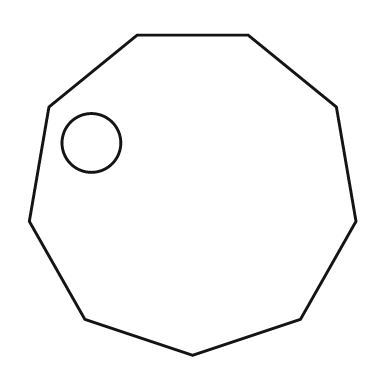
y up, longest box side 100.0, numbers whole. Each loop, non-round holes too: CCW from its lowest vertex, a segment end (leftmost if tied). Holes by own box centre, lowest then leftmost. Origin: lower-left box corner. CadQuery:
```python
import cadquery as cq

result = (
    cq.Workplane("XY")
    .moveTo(50.0, 0.0)
    .lineTo(83.0, 11.0)
    .lineTo(100.0, 41.0)
    .lineTo(94.0, 76.0)
    .lineTo(67.0, 98.0)
    .lineTo(33.0, 98.0)
    .lineTo(6.0, 76.0)
    .lineTo(0.0, 41.0)
    .lineTo(17.0, 11.0)
    .close()
    .moveTo(19.0, 65.0)
    .circle(9.0)
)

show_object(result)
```